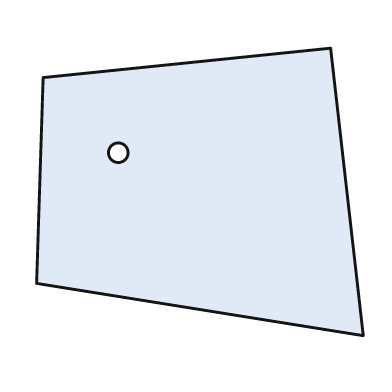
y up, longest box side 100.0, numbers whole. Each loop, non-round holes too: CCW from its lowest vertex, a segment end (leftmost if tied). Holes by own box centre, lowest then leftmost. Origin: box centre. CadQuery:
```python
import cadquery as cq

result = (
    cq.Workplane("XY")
    .moveTo(50.0, -44.0)
    .lineTo(40.0, 44.0)
    .lineTo(-48.0, 35.0)
    .lineTo(-50.0, -28.0)
    .close()
    .moveTo(-25.0, 12.0)
    .circle(3.0)
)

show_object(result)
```